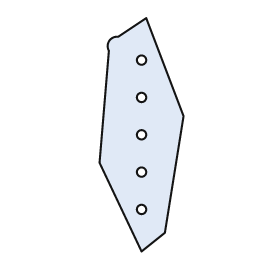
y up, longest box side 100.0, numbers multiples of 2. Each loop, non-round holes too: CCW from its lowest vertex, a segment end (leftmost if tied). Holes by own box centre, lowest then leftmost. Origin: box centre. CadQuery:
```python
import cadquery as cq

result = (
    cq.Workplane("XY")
    .moveTo(0.0, -50.0)
    .lineTo(10.0, -42.0)
    .lineTo(18.0, 8.0)
    .lineTo(2.0, 50.0)
    .lineTo(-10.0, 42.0)
    .threePointArc((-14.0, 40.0), (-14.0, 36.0))
    .lineTo(-18.0, -12.0)
    .close()
    .moveTo(0.0, -32.0)
    .circle(2.0)
    .moveTo(0.0, -16.0)
    .circle(2.0)
    .moveTo(0.0, 0.0)
    .circle(2.0)
    .moveTo(0.0, 16.0)
    .circle(2.0)
    .moveTo(0.0, 32.0)
    .circle(2.0)
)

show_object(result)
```